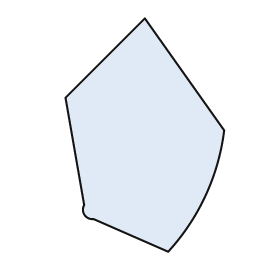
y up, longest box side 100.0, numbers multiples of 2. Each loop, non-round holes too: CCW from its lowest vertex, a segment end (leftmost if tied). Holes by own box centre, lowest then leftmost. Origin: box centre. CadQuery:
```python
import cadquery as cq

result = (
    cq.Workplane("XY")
    .moveTo(10.0, -50.0)
    .threePointArc((26.0, -26.0), (34.0, 2.0))
    .lineTo(0.0, 50.0)
    .lineTo(-34.0, 16.0)
    .lineTo(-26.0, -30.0)
    .threePointArc((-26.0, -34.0), (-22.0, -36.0))
    .close()
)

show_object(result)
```